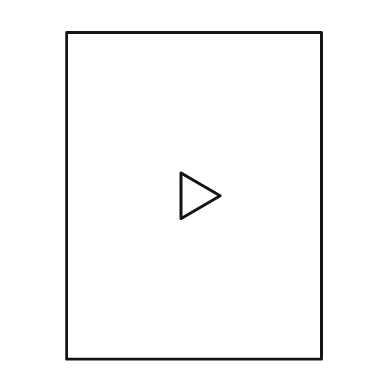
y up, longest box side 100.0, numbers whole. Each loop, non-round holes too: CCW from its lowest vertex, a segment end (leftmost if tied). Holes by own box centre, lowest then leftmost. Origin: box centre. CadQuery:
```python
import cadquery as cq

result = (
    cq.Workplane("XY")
    .moveTo(-39.0, -50.0)
    .lineTo(39.0, -50.0)
    .lineTo(39.0, 50.0)
    .lineTo(-39.0, 50.0)
    .close()
    .moveTo(-4.0, -7.0)
    .lineTo(8.0, 0.0)
    .lineTo(-4.0, 7.0)
    .close()
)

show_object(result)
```